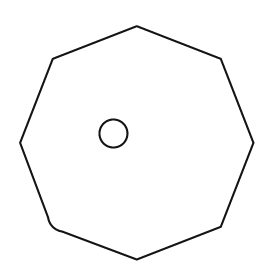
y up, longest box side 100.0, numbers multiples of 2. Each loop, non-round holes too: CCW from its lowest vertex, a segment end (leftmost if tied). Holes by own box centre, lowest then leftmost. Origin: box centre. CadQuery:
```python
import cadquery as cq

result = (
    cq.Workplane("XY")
    .moveTo(0.0, -50.0)
    .lineTo(36.0, -36.0)
    .lineTo(50.0, 0.0)
    .lineTo(36.0, 36.0)
    .lineTo(0.0, 50.0)
    .lineTo(-36.0, 36.0)
    .lineTo(-50.0, 0.0)
    .lineTo(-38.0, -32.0)
    .threePointArc((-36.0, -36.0), (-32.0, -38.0))
    .close()
    .moveTo(-10.0, 4.0)
    .circle(6.0)
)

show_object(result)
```